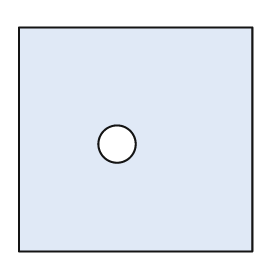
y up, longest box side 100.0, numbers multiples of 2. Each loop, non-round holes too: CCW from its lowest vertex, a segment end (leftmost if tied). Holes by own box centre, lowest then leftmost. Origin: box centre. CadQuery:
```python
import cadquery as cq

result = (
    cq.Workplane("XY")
    .moveTo(-50.0, -48.0)
    .lineTo(50.0, -48.0)
    .lineTo(50.0, 48.0)
    .lineTo(-50.0, 48.0)
    .close()
    .moveTo(-8.0, -2.0)
    .circle(8.0)
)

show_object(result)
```